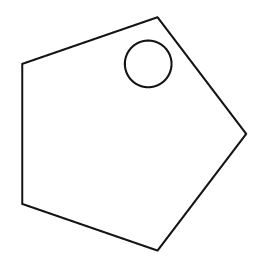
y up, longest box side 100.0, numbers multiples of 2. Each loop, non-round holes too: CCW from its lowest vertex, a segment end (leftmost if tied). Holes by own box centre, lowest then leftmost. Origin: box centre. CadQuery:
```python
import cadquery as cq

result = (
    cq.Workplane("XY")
    .moveTo(10.0, -50.0)
    .lineTo(48.0, 0.0)
    .lineTo(10.0, 50.0)
    .lineTo(-48.0, 30.0)
    .lineTo(-48.0, -30.0)
    .close()
    .moveTo(6.0, 30.0)
    .circle(10.0)
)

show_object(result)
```